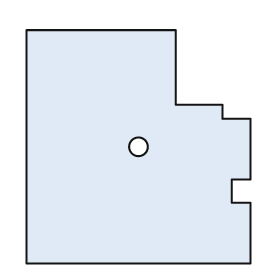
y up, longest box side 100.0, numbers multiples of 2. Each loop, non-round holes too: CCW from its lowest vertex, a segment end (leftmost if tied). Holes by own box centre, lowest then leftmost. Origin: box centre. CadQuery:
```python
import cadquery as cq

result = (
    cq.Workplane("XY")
    .moveTo(-48.0, -50.0)
    .lineTo(48.0, -50.0)
    .lineTo(48.0, -24.0)
    .lineTo(40.0, -24.0)
    .lineTo(40.0, -14.0)
    .lineTo(48.0, -14.0)
    .lineTo(48.0, 12.0)
    .lineTo(36.0, 12.0)
    .lineTo(36.0, 18.0)
    .lineTo(16.0, 18.0)
    .lineTo(16.0, 50.0)
    .lineTo(-48.0, 50.0)
    .close()
    .moveTo(0.0, 0.0)
    .circle(4.0)
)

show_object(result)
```